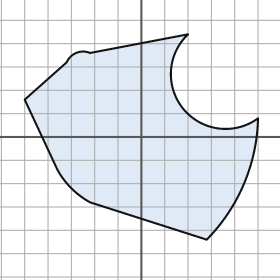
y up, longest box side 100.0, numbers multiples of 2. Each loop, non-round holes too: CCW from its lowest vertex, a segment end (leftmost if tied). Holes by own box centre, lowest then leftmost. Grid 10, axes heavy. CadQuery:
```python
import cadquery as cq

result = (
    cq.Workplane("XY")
    .moveTo(28.0, -44.0)
    .threePointArc((44.0, -20.0), (50.0, 8.0))
    .threePointArc((18.0, 12.0), (20.0, 44.0))
    .lineTo(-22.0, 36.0)
    .threePointArc((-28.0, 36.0), (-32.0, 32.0))
    .lineTo(-50.0, 16.0)
    .lineTo(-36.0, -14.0)
    .threePointArc((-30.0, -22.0), (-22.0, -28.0))
    .close()
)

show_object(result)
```